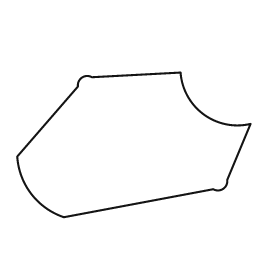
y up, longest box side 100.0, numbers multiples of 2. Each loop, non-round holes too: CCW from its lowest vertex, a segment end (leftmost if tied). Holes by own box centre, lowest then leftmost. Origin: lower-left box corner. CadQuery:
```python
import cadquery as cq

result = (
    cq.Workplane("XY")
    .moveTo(20.0, 0.0)
    .lineTo(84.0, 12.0)
    .threePointArc((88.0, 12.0), (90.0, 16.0))
    .lineTo(100.0, 40.0)
    .threePointArc((80.0, 44.0), (70.0, 62.0))
    .lineTo(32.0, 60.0)
    .threePointArc((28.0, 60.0), (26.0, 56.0))
    .lineTo(0.0, 26.0)
    .threePointArc((6.0, 10.0), (20.0, 0.0))
    .close()
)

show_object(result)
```